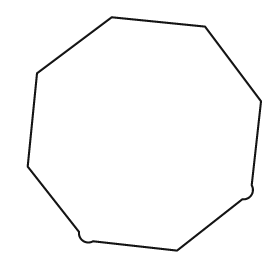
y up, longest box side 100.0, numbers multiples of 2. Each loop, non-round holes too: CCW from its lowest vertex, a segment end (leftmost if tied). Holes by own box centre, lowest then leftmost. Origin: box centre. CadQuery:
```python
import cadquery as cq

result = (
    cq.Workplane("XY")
    .moveTo(14.0, -50.0)
    .lineTo(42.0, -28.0)
    .threePointArc((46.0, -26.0), (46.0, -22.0))
    .lineTo(50.0, 14.0)
    .lineTo(26.0, 46.0)
    .lineTo(-14.0, 50.0)
    .lineTo(-46.0, 26.0)
    .lineTo(-50.0, -14.0)
    .lineTo(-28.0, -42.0)
    .threePointArc((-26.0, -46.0), (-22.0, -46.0))
    .close()
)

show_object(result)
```